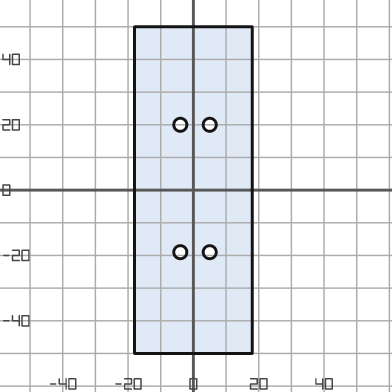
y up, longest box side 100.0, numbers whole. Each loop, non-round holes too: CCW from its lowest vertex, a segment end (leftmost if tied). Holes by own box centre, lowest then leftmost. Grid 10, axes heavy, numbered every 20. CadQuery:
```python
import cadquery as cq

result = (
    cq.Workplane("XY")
    .moveTo(-18.0, -50.0)
    .lineTo(18.0, -50.0)
    .lineTo(18.0, 50.0)
    .lineTo(-18.0, 50.0)
    .close()
    .moveTo(-4.0, -19.0)
    .circle(2.0)
    .moveTo(5.0, -19.0)
    .circle(2.0)
    .moveTo(-4.0, 20.0)
    .circle(2.0)
    .moveTo(5.0, 20.0)
    .circle(2.0)
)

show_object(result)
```